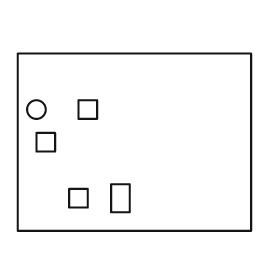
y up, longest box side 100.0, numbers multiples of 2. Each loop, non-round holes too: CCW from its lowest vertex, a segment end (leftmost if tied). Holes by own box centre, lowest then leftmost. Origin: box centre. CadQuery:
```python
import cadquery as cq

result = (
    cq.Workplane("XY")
    .moveTo(-50.0, -38.0)
    .lineTo(50.0, -38.0)
    .lineTo(50.0, 38.0)
    .lineTo(-50.0, 38.0)
    .close()
    .moveTo(-28.0, -28.0)
    .lineTo(-20.0, -28.0)
    .lineTo(-20.0, -20.0)
    .lineTo(-28.0, -20.0)
    .close()
    .moveTo(-10.0, -30.0)
    .lineTo(-2.0, -30.0)
    .lineTo(-2.0, -18.0)
    .lineTo(-10.0, -18.0)
    .close()
    .moveTo(-42.0, -4.0)
    .lineTo(-34.0, -4.0)
    .lineTo(-34.0, 4.0)
    .lineTo(-42.0, 4.0)
    .close()
    .moveTo(-42.0, 14.0)
    .circle(4.0)
    .moveTo(-24.0, 10.0)
    .lineTo(-16.0, 10.0)
    .lineTo(-16.0, 18.0)
    .lineTo(-24.0, 18.0)
    .close()
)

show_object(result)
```